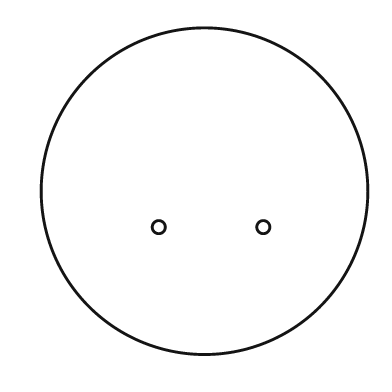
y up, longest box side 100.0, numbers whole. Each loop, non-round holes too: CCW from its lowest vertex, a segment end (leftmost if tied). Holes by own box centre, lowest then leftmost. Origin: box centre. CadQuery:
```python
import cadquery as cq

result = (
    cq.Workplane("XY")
    .moveTo(0.0, 0.0)
    .circle(50.0)
    .moveTo(-14.0, -11.0)
    .circle(2.0)
    .moveTo(18.0, -11.0)
    .circle(2.0)
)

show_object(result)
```